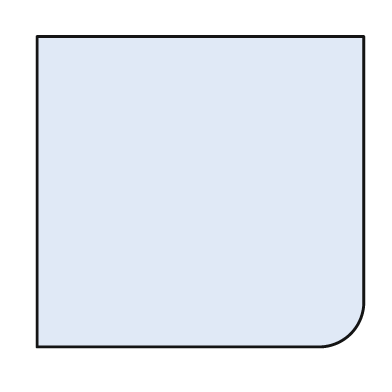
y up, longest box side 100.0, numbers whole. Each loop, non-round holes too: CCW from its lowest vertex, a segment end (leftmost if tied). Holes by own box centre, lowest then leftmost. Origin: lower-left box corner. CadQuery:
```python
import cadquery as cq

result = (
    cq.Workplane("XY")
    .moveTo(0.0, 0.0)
    .lineTo(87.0, 0.0)
    .threePointArc((96.0, 4.0), (100.0, 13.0))
    .lineTo(100.0, 95.0)
    .lineTo(0.0, 95.0)
    .close()
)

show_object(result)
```